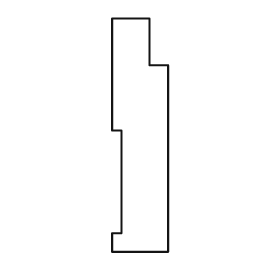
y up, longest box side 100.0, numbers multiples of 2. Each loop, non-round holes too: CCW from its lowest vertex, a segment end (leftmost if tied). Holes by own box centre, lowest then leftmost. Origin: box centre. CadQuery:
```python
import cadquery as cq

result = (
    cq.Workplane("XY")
    .moveTo(-12.0, -50.0)
    .lineTo(12.0, -50.0)
    .lineTo(12.0, 30.0)
    .lineTo(4.0, 30.0)
    .lineTo(4.0, 50.0)
    .lineTo(-12.0, 50.0)
    .lineTo(-12.0, 2.0)
    .lineTo(-8.0, 2.0)
    .lineTo(-8.0, -42.0)
    .lineTo(-12.0, -42.0)
    .close()
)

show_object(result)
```